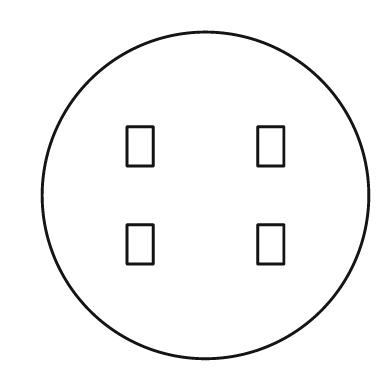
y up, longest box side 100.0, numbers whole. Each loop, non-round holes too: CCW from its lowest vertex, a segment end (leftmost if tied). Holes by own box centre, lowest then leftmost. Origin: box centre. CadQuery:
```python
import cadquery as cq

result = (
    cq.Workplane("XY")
    .moveTo(0.0, 0.0)
    .circle(50.0)
    .moveTo(-24.0, -21.0)
    .lineTo(-16.0, -21.0)
    .lineTo(-16.0, -9.0)
    .lineTo(-24.0, -9.0)
    .close()
    .moveTo(16.0, -21.0)
    .lineTo(24.0, -21.0)
    .lineTo(24.0, -9.0)
    .lineTo(16.0, -9.0)
    .close()
    .moveTo(-24.0, 9.0)
    .lineTo(-16.0, 9.0)
    .lineTo(-16.0, 21.0)
    .lineTo(-24.0, 21.0)
    .close()
    .moveTo(16.0, 9.0)
    .lineTo(24.0, 9.0)
    .lineTo(24.0, 21.0)
    .lineTo(16.0, 21.0)
    .close()
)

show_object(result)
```